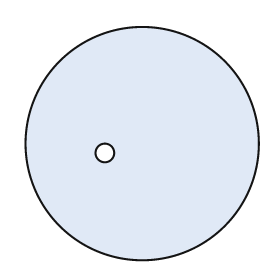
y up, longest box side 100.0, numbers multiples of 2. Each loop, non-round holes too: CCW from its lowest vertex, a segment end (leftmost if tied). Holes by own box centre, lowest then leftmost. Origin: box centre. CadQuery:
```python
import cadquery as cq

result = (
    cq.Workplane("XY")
    .moveTo(0.0, 0.0)
    .circle(50.0)
    .moveTo(-16.0, -4.0)
    .circle(4.0)
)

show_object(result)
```